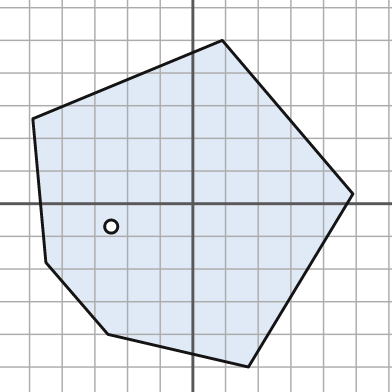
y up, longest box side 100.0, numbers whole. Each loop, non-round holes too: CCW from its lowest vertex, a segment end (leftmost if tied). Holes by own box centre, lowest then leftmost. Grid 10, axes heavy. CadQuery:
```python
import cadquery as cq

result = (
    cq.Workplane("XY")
    .moveTo(17.0, -50.0)
    .lineTo(49.0, 3.0)
    .lineTo(9.0, 50.0)
    .lineTo(-49.0, 26.0)
    .lineTo(-45.0, -18.0)
    .lineTo(-26.0, -40.0)
    .close()
    .moveTo(-25.0, -7.0)
    .circle(2.0)
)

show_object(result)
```